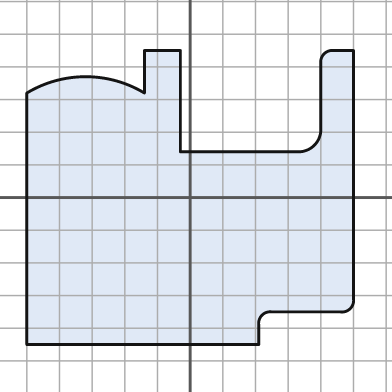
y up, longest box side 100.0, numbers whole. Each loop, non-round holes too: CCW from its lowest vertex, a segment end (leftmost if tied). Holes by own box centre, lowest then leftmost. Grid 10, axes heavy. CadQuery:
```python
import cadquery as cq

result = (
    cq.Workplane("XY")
    .moveTo(-50.0, -45.0)
    .lineTo(21.0, -45.0)
    .lineTo(21.0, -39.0)
    .threePointArc((22.0, -36.0), (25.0, -35.0))
    .lineTo(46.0, -35.0)
    .threePointArc((49.0, -34.0), (50.0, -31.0))
    .lineTo(50.0, 45.0)
    .lineTo(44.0, 45.0)
    .threePointArc((41.0, 44.0), (40.0, 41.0))
    .lineTo(40.0, 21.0)
    .threePointArc((38.0, 16.0), (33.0, 14.0))
    .lineTo(-3.0, 14.0)
    .lineTo(-3.0, 45.0)
    .lineTo(-14.0, 45.0)
    .lineTo(-14.0, 32.0)
    .threePointArc((-32.0, 37.0), (-50.0, 32.0))
    .close()
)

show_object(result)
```